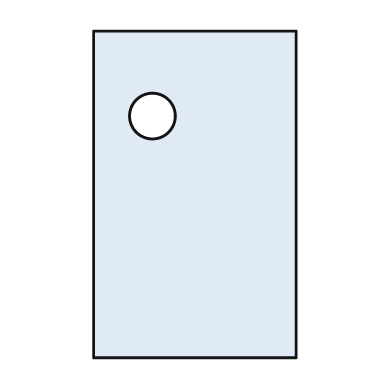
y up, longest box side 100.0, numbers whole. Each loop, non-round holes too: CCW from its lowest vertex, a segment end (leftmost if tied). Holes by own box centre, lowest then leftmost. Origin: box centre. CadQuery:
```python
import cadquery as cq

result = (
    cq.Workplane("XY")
    .moveTo(-31.0, -50.0)
    .lineTo(31.0, -50.0)
    .lineTo(31.0, 50.0)
    .lineTo(-31.0, 50.0)
    .close()
    .moveTo(-13.0, 24.0)
    .circle(7.0)
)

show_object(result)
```